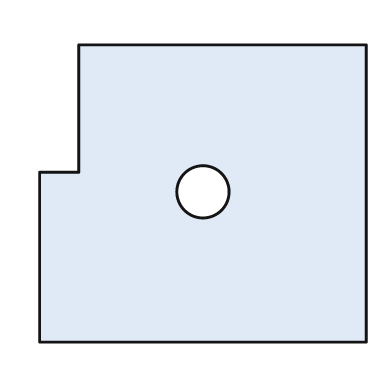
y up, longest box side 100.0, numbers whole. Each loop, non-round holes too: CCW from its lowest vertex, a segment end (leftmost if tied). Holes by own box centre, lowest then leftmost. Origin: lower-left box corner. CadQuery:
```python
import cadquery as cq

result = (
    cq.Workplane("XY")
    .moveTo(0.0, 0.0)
    .lineTo(100.0, 0.0)
    .lineTo(100.0, 91.0)
    .lineTo(12.0, 91.0)
    .lineTo(12.0, 52.0)
    .lineTo(0.0, 52.0)
    .close()
    .moveTo(50.0, 46.0)
    .circle(8.0)
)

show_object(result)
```